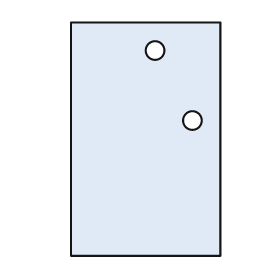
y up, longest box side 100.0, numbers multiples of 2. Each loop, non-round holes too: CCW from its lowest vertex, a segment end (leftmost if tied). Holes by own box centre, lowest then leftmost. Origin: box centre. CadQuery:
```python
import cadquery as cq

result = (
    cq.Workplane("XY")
    .moveTo(-32.0, -50.0)
    .lineTo(32.0, -50.0)
    .lineTo(32.0, 50.0)
    .lineTo(-32.0, 50.0)
    .close()
    .moveTo(20.0, 8.0)
    .circle(4.0)
    .moveTo(4.0, 38.0)
    .circle(4.0)
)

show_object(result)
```